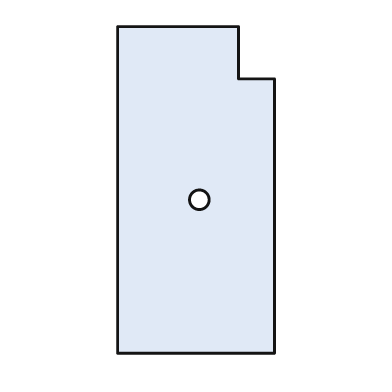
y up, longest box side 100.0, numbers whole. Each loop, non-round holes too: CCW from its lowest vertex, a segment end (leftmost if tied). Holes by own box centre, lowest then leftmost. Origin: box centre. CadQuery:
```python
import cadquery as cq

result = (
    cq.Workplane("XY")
    .moveTo(-24.0, -50.0)
    .lineTo(24.0, -50.0)
    .lineTo(24.0, 34.0)
    .lineTo(13.0, 34.0)
    .lineTo(13.0, 50.0)
    .lineTo(-24.0, 50.0)
    .close()
    .moveTo(1.0, -3.0)
    .circle(3.0)
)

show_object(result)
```